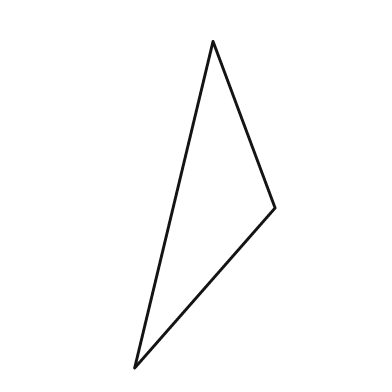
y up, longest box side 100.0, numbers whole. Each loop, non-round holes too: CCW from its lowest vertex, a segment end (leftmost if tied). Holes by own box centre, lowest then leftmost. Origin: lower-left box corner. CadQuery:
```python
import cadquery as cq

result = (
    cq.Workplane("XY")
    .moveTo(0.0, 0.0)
    .lineTo(43.0, 49.0)
    .lineTo(24.0, 100.0)
    .close()
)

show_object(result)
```